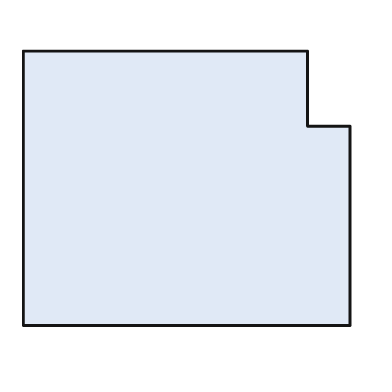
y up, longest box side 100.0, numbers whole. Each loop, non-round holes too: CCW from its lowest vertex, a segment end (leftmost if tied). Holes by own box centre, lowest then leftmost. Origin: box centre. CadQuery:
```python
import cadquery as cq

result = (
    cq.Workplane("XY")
    .moveTo(-50.0, -42.0)
    .lineTo(50.0, -42.0)
    .lineTo(50.0, 19.0)
    .lineTo(37.0, 19.0)
    .lineTo(37.0, 42.0)
    .lineTo(-50.0, 42.0)
    .close()
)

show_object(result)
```